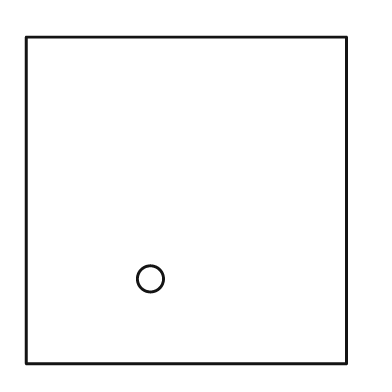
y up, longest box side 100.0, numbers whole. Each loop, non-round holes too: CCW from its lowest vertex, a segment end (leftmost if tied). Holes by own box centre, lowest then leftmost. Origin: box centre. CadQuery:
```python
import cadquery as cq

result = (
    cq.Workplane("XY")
    .moveTo(-49.0, -50.0)
    .lineTo(49.0, -50.0)
    .lineTo(49.0, 50.0)
    .lineTo(-49.0, 50.0)
    .close()
    .moveTo(-11.0, -24.0)
    .circle(4.0)
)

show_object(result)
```